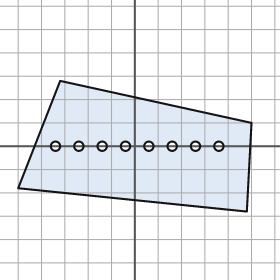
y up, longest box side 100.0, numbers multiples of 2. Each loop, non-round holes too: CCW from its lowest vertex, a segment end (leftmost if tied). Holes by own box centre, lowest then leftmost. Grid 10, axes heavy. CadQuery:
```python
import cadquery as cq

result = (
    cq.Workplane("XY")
    .moveTo(48.0, -28.0)
    .lineTo(50.0, 10.0)
    .lineTo(-32.0, 28.0)
    .lineTo(-50.0, -18.0)
    .close()
    .moveTo(-34.0, 0.0)
    .circle(2.0)
    .moveTo(-24.0, 0.0)
    .circle(2.0)
    .moveTo(-14.0, 0.0)
    .circle(2.0)
    .moveTo(-4.0, 0.0)
    .circle(2.0)
    .moveTo(6.0, 0.0)
    .circle(2.0)
    .moveTo(16.0, 0.0)
    .circle(2.0)
    .moveTo(26.0, 0.0)
    .circle(2.0)
    .moveTo(36.0, 0.0)
    .circle(2.0)
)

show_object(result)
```